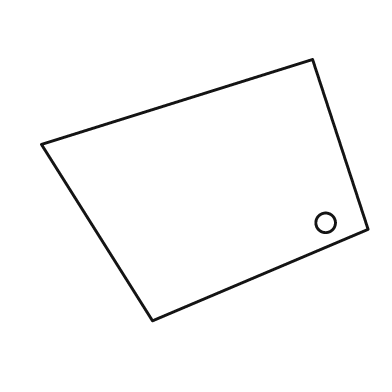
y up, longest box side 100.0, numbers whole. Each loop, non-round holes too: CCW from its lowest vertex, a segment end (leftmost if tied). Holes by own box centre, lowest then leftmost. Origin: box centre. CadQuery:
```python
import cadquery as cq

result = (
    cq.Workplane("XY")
    .moveTo(-16.0, -40.0)
    .lineTo(50.0, -12.0)
    .lineTo(33.0, 40.0)
    .lineTo(-50.0, 14.0)
    .close()
    .moveTo(37.0, -10.0)
    .circle(3.0)
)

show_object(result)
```